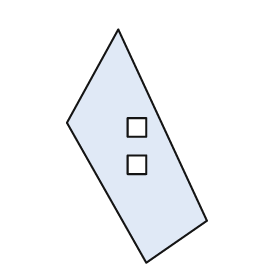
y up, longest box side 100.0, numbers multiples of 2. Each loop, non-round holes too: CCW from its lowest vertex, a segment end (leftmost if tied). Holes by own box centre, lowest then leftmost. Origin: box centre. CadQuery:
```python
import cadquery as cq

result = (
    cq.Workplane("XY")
    .moveTo(4.0, -50.0)
    .lineTo(30.0, -32.0)
    .lineTo(-8.0, 50.0)
    .lineTo(-30.0, 10.0)
    .close()
    .moveTo(-4.0, -12.0)
    .lineTo(4.0, -12.0)
    .lineTo(4.0, -4.0)
    .lineTo(-4.0, -4.0)
    .close()
    .moveTo(-4.0, 4.0)
    .lineTo(4.0, 4.0)
    .lineTo(4.0, 12.0)
    .lineTo(-4.0, 12.0)
    .close()
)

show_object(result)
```